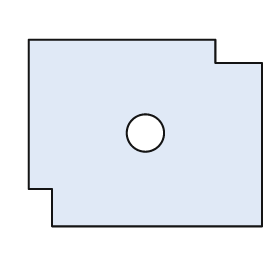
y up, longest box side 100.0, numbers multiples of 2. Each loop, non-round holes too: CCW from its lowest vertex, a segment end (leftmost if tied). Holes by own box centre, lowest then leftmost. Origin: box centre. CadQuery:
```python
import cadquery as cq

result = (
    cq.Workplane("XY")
    .moveTo(-40.0, -40.0)
    .lineTo(50.0, -40.0)
    .lineTo(50.0, 30.0)
    .lineTo(30.0, 30.0)
    .lineTo(30.0, 40.0)
    .lineTo(-50.0, 40.0)
    .lineTo(-50.0, -24.0)
    .lineTo(-40.0, -24.0)
    .close()
    .moveTo(0.0, 0.0)
    .circle(8.0)
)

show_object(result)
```